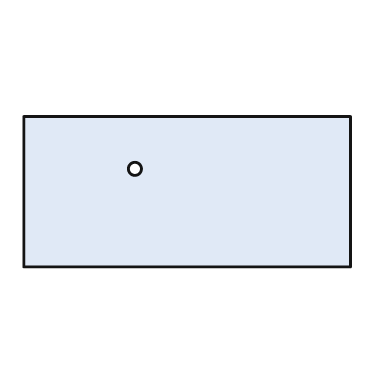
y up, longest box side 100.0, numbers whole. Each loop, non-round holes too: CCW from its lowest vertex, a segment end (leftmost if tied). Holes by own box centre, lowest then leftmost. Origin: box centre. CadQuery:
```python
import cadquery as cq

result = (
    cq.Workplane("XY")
    .moveTo(-50.0, -23.0)
    .lineTo(50.0, -23.0)
    .lineTo(50.0, 23.0)
    .lineTo(-50.0, 23.0)
    .close()
    .moveTo(-16.0, 7.0)
    .circle(2.0)
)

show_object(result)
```